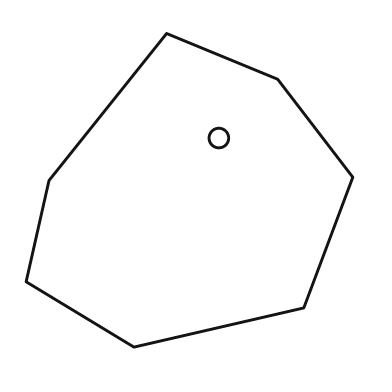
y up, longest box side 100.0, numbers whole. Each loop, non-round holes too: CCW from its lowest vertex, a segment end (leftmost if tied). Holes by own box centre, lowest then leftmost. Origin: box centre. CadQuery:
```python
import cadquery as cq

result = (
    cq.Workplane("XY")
    .moveTo(-17.0, -48.0)
    .lineTo(35.0, -36.0)
    .lineTo(50.0, 4.0)
    .lineTo(27.0, 34.0)
    .lineTo(-7.0, 48.0)
    .lineTo(-43.0, 3.0)
    .lineTo(-50.0, -28.0)
    .close()
    .moveTo(9.0, 16.0)
    .circle(3.0)
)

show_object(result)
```